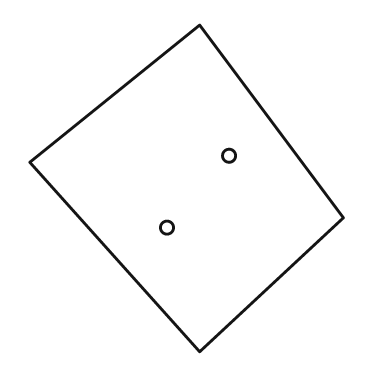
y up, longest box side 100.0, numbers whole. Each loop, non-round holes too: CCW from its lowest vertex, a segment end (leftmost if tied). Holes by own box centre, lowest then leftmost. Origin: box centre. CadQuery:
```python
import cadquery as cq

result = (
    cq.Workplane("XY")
    .moveTo(4.0, -50.0)
    .lineTo(48.0, -9.0)
    .lineTo(4.0, 50.0)
    .lineTo(-48.0, 8.0)
    .close()
    .moveTo(-6.0, -12.0)
    .circle(2.0)
    .moveTo(13.0, 10.0)
    .circle(2.0)
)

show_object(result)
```